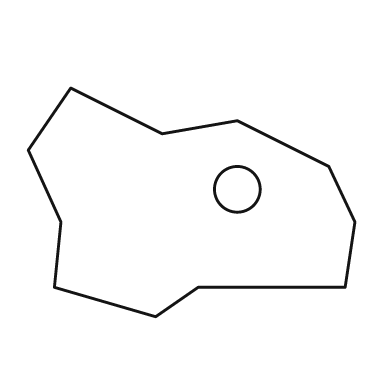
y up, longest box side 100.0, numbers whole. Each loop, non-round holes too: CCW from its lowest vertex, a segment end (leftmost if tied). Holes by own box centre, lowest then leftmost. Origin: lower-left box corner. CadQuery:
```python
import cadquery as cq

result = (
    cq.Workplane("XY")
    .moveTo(39.0, 0.0)
    .lineTo(52.0, 9.0)
    .lineTo(97.0, 9.0)
    .lineTo(100.0, 29.0)
    .lineTo(92.0, 46.0)
    .lineTo(64.0, 60.0)
    .lineTo(41.0, 56.0)
    .lineTo(13.0, 70.0)
    .lineTo(0.0, 51.0)
    .lineTo(10.0, 29.0)
    .lineTo(8.0, 9.0)
    .close()
    .moveTo(64.0, 39.0)
    .circle(7.0)
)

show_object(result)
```